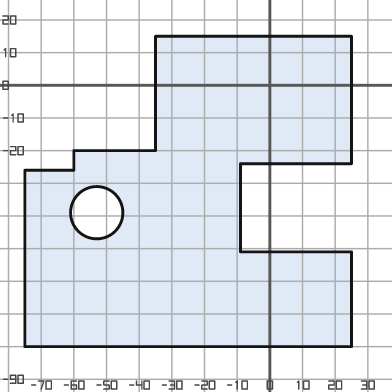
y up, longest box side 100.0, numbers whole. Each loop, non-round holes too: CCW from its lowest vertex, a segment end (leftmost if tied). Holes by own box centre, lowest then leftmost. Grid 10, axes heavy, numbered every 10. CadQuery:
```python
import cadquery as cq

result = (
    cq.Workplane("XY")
    .moveTo(-75.0, -80.0)
    .lineTo(25.0, -80.0)
    .lineTo(25.0, -51.0)
    .lineTo(-9.0, -51.0)
    .lineTo(-9.0, -24.0)
    .lineTo(25.0, -24.0)
    .lineTo(25.0, 15.0)
    .lineTo(-35.0, 15.0)
    .lineTo(-35.0, -20.0)
    .lineTo(-60.0, -20.0)
    .lineTo(-60.0, -26.0)
    .lineTo(-75.0, -26.0)
    .close()
    .moveTo(-53.0, -39.0)
    .circle(8.0)
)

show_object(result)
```